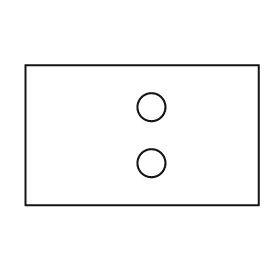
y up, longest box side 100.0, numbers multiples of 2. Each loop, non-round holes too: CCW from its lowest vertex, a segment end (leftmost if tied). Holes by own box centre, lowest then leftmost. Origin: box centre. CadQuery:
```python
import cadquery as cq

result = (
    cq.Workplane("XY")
    .moveTo(-50.0, -30.0)
    .lineTo(50.0, -30.0)
    .lineTo(50.0, 30.0)
    .lineTo(-50.0, 30.0)
    .close()
    .moveTo(4.0, -12.0)
    .circle(6.0)
    .moveTo(4.0, 12.0)
    .circle(6.0)
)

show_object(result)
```